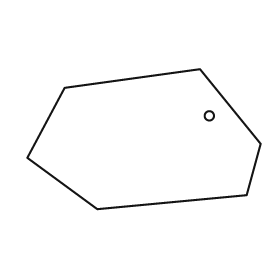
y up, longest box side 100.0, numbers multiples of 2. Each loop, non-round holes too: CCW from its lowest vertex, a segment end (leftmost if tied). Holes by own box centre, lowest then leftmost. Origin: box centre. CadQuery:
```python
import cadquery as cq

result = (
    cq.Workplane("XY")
    .moveTo(-20.0, -30.0)
    .lineTo(44.0, -24.0)
    .lineTo(50.0, -2.0)
    .lineTo(24.0, 30.0)
    .lineTo(-34.0, 22.0)
    .lineTo(-50.0, -8.0)
    .close()
    .moveTo(28.0, 10.0)
    .circle(2.0)
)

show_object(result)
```